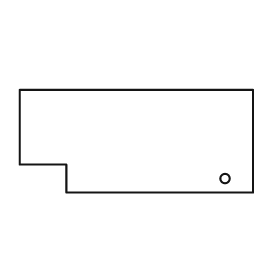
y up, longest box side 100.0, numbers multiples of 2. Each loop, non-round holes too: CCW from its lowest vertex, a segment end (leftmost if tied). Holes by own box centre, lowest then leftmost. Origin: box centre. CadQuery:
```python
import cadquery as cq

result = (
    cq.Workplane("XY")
    .moveTo(-30.0, -22.0)
    .lineTo(50.0, -22.0)
    .lineTo(50.0, 22.0)
    .lineTo(-50.0, 22.0)
    .lineTo(-50.0, -10.0)
    .lineTo(-30.0, -10.0)
    .close()
    .moveTo(38.0, -16.0)
    .circle(2.0)
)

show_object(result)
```